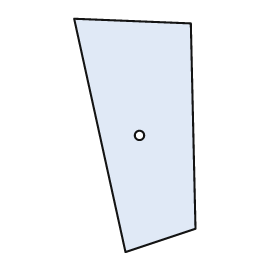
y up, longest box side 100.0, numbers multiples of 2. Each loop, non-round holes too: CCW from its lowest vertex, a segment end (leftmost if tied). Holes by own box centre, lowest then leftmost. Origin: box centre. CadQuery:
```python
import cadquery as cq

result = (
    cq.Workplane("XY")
    .moveTo(-4.0, -50.0)
    .lineTo(26.0, -40.0)
    .lineTo(24.0, 48.0)
    .lineTo(-26.0, 50.0)
    .close()
    .moveTo(2.0, 0.0)
    .circle(2.0)
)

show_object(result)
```